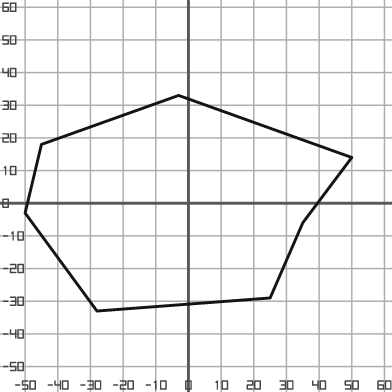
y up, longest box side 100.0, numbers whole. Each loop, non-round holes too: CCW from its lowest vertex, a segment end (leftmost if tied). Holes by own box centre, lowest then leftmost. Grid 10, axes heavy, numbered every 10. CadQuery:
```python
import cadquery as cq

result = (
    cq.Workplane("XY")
    .moveTo(-28.0, -33.0)
    .lineTo(25.0, -29.0)
    .lineTo(35.0, -6.0)
    .lineTo(50.0, 14.0)
    .lineTo(-3.0, 33.0)
    .lineTo(-45.0, 18.0)
    .lineTo(-50.0, -3.0)
    .close()
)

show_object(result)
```